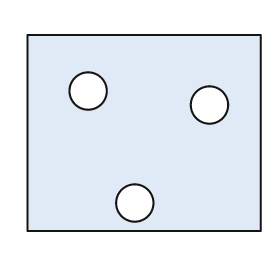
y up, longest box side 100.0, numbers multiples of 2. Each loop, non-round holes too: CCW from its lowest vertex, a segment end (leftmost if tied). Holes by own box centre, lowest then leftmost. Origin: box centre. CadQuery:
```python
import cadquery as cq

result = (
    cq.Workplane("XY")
    .moveTo(-50.0, -42.0)
    .lineTo(50.0, -42.0)
    .lineTo(50.0, 42.0)
    .lineTo(-50.0, 42.0)
    .close()
    .moveTo(-4.0, -30.0)
    .circle(8.0)
    .moveTo(28.0, 12.0)
    .circle(8.0)
    .moveTo(-24.0, 18.0)
    .circle(8.0)
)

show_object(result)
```